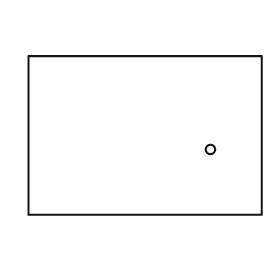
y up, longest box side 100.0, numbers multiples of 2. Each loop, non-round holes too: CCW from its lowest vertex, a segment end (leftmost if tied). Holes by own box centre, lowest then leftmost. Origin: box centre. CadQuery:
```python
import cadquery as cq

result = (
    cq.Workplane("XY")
    .moveTo(-50.0, -34.0)
    .lineTo(50.0, -34.0)
    .lineTo(50.0, 34.0)
    .lineTo(-50.0, 34.0)
    .close()
    .moveTo(28.0, -6.0)
    .circle(2.0)
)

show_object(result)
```